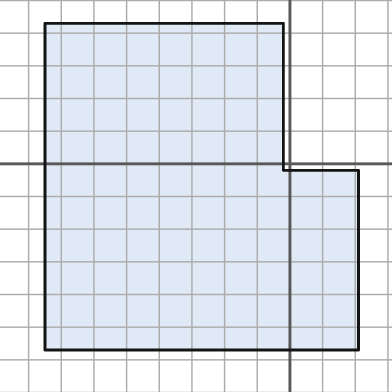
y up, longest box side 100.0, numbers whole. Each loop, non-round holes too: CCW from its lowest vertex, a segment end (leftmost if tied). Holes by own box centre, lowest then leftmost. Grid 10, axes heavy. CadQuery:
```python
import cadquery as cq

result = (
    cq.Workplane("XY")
    .moveTo(-75.0, -57.0)
    .lineTo(21.0, -57.0)
    .lineTo(21.0, -2.0)
    .lineTo(-2.0, -2.0)
    .lineTo(-2.0, 43.0)
    .lineTo(-75.0, 43.0)
    .close()
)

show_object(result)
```